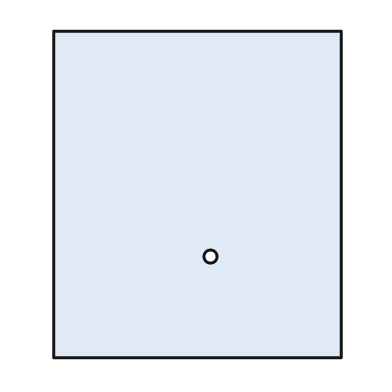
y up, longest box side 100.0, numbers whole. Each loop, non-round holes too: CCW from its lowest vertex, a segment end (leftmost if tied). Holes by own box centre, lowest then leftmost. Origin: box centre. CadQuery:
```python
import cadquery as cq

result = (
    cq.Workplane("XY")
    .moveTo(-44.0, -50.0)
    .lineTo(44.0, -50.0)
    .lineTo(44.0, 50.0)
    .lineTo(-44.0, 50.0)
    .close()
    .moveTo(4.0, -19.0)
    .circle(2.0)
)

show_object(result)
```